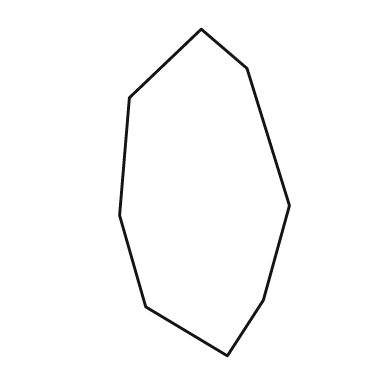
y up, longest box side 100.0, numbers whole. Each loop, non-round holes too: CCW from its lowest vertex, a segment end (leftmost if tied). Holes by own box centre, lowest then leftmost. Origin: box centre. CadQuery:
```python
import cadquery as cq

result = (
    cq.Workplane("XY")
    .moveTo(7.0, -50.0)
    .lineTo(18.0, -33.0)
    .lineTo(26.0, -4.0)
    .lineTo(13.0, 38.0)
    .lineTo(-1.0, 50.0)
    .lineTo(-23.0, 29.0)
    .lineTo(-26.0, -7.0)
    .lineTo(-18.0, -35.0)
    .close()
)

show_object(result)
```